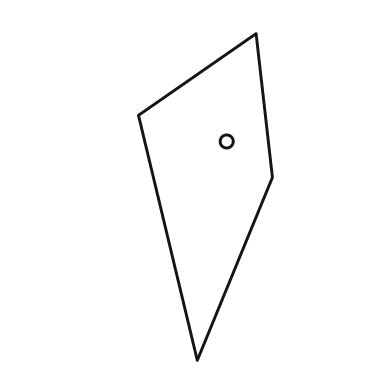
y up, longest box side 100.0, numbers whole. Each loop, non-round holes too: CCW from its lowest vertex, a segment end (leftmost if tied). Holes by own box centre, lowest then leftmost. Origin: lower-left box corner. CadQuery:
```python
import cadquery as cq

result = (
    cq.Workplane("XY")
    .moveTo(18.0, 0.0)
    .lineTo(41.0, 56.0)
    .lineTo(36.0, 100.0)
    .lineTo(0.0, 75.0)
    .close()
    .moveTo(27.0, 67.0)
    .circle(2.0)
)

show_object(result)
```